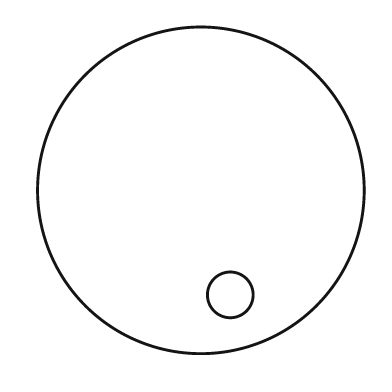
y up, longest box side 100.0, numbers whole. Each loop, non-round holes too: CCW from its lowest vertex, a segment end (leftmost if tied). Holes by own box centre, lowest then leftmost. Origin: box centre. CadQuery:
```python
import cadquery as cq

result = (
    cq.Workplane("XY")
    .moveTo(0.0, 0.0)
    .circle(50.0)
    .moveTo(9.0, -32.0)
    .circle(7.0)
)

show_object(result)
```